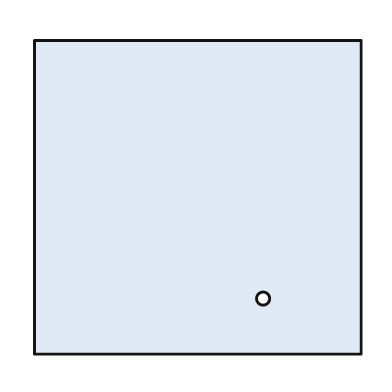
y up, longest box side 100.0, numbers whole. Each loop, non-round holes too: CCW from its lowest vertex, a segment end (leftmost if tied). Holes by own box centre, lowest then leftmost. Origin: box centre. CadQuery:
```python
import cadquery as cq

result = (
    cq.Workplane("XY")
    .moveTo(-50.0, -48.0)
    .lineTo(50.0, -48.0)
    .lineTo(50.0, 48.0)
    .lineTo(-50.0, 48.0)
    .close()
    .moveTo(20.0, -31.0)
    .circle(2.0)
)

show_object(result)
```